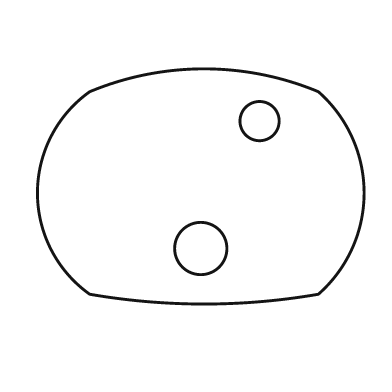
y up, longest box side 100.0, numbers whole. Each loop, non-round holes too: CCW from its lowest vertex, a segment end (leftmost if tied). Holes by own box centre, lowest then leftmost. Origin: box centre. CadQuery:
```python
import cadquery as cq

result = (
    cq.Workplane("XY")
    .moveTo(-34.0, -33.0)
    .threePointArc((1.0, -36.0), (36.0, -33.0))
    .threePointArc((50.0, -2.0), (36.0, 29.0))
    .threePointArc((1.0, 36.0), (-34.0, 29.0))
    .threePointArc((-50.0, -2.0), (-34.0, -33.0))
    .close()
    .moveTo(0.0, -19.0)
    .circle(8.0)
    .moveTo(18.0, 20.0)
    .circle(6.0)
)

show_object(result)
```